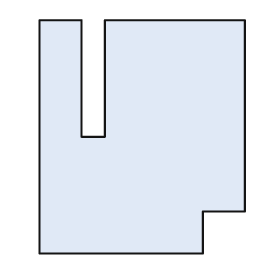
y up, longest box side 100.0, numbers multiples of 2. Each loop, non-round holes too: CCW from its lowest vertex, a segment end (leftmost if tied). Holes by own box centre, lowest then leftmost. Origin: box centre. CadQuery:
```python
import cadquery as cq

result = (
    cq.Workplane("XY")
    .moveTo(-44.0, -50.0)
    .lineTo(26.0, -50.0)
    .lineTo(26.0, -32.0)
    .lineTo(44.0, -32.0)
    .lineTo(44.0, 50.0)
    .lineTo(-16.0, 50.0)
    .lineTo(-16.0, 0.0)
    .lineTo(-26.0, 0.0)
    .lineTo(-26.0, 50.0)
    .lineTo(-44.0, 50.0)
    .close()
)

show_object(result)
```